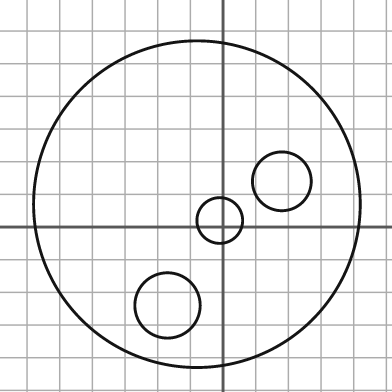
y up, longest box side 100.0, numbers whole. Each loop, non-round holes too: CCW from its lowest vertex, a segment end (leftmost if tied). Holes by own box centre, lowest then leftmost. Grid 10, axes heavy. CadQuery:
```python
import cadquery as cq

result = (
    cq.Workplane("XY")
    .moveTo(-8.0, 7.0)
    .circle(50.0)
    .moveTo(-17.0, -24.0)
    .circle(10.0)
    .moveTo(-1.0, 2.0)
    .circle(7.0)
    .moveTo(18.0, 14.0)
    .circle(9.0)
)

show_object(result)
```